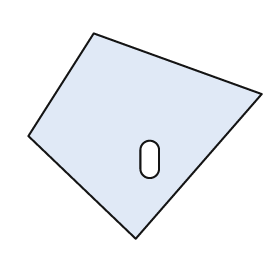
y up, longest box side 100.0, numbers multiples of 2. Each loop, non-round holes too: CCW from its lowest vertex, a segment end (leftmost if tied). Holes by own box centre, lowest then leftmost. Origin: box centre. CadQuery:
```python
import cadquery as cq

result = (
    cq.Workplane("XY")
    .moveTo(-4.0, -44.0)
    .lineTo(50.0, 18.0)
    .lineTo(-22.0, 44.0)
    .lineTo(-50.0, 0.0)
    .close()
    .moveTo(-2.0, -14.0)
    .threePointArc((2.0, -18.0), (6.0, -14.0))
    .lineTo(6.0, -6.0)
    .threePointArc((2.0, -2.0), (-2.0, -6.0))
    .close()
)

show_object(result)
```